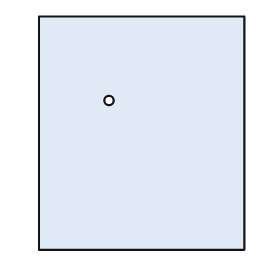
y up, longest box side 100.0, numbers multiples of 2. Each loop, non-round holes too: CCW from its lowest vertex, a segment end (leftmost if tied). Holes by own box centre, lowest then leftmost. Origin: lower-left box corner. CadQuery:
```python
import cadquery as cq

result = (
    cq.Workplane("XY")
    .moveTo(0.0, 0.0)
    .lineTo(88.0, 0.0)
    .lineTo(88.0, 100.0)
    .lineTo(0.0, 100.0)
    .close()
    .moveTo(30.0, 64.0)
    .circle(2.0)
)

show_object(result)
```